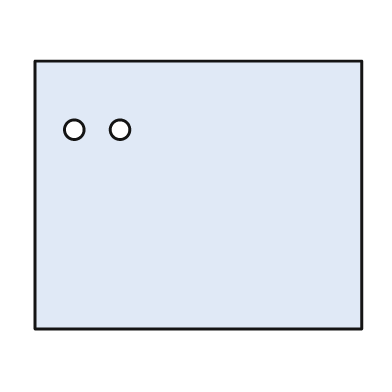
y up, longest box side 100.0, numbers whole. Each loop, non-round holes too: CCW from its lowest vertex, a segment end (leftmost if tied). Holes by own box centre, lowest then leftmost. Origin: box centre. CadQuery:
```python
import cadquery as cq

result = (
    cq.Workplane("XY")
    .moveTo(-50.0, -41.0)
    .lineTo(50.0, -41.0)
    .lineTo(50.0, 41.0)
    .lineTo(-50.0, 41.0)
    .close()
    .moveTo(-38.0, 20.0)
    .circle(3.0)
    .moveTo(-24.0, 20.0)
    .circle(3.0)
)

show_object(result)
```